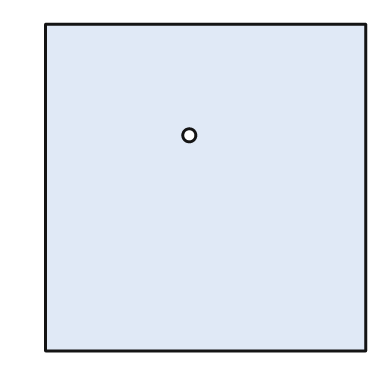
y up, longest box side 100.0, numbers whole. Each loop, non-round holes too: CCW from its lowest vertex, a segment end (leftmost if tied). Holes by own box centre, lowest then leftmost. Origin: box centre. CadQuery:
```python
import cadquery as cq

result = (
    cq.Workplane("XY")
    .moveTo(-49.0, -50.0)
    .lineTo(49.0, -50.0)
    .lineTo(49.0, 50.0)
    .lineTo(-49.0, 50.0)
    .close()
    .moveTo(-5.0, 16.0)
    .circle(2.0)
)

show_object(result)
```